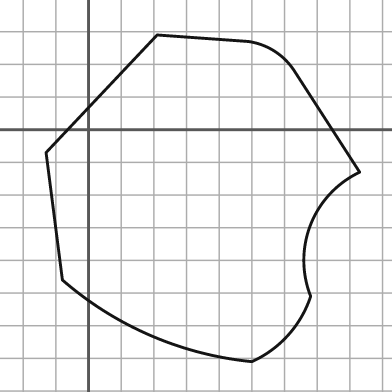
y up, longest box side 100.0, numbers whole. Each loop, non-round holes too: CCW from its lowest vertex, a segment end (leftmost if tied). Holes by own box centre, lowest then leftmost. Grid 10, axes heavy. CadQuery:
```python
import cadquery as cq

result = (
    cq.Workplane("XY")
    .moveTo(50.0, -71.0)
    .threePointArc((61.0, -63.0), (68.0, -51.0))
    .threePointArc((68.0, -29.0), (83.0, -13.0))
    .lineTo(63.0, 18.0)
    .threePointArc((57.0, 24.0), (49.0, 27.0))
    .lineTo(21.0, 29.0)
    .lineTo(-13.0, -7.0)
    .lineTo(-8.0, -46.0)
    .threePointArc((19.0, -63.0), (50.0, -71.0))
    .close()
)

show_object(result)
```